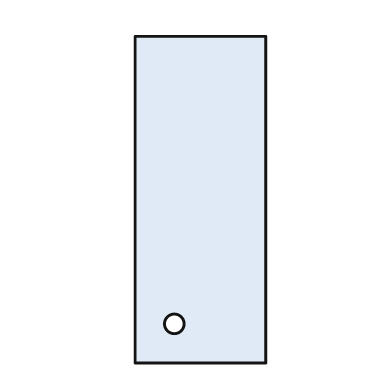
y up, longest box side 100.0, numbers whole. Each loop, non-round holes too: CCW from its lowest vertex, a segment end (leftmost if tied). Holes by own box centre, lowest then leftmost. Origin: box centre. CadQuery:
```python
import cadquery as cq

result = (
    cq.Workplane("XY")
    .moveTo(-20.0, -50.0)
    .lineTo(20.0, -50.0)
    .lineTo(20.0, 50.0)
    .lineTo(-20.0, 50.0)
    .close()
    .moveTo(-8.0, -38.0)
    .circle(3.0)
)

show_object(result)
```